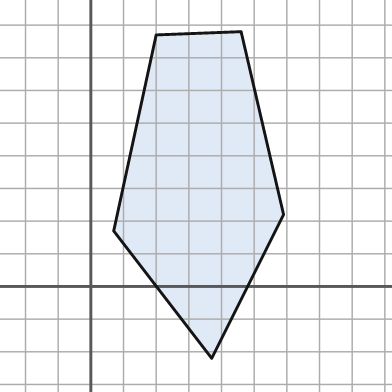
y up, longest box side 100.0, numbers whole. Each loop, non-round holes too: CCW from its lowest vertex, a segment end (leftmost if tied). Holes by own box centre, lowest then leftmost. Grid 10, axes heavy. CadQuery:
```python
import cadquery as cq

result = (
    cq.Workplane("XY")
    .moveTo(37.0, -22.0)
    .lineTo(59.0, 22.0)
    .lineTo(46.0, 78.0)
    .lineTo(20.0, 77.0)
    .lineTo(7.0, 17.0)
    .close()
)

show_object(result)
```